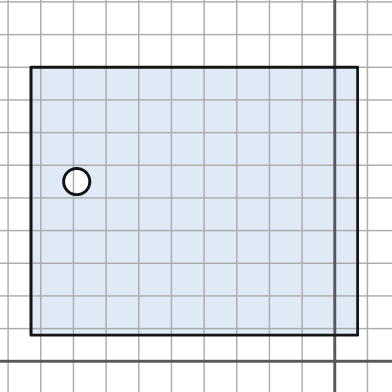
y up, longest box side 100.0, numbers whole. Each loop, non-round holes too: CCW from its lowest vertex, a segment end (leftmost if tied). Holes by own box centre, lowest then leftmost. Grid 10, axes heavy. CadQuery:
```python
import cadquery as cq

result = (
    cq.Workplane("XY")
    .moveTo(-93.0, 8.0)
    .lineTo(7.0, 8.0)
    .lineTo(7.0, 90.0)
    .lineTo(-93.0, 90.0)
    .close()
    .moveTo(-79.0, 55.0)
    .circle(4.0)
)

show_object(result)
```